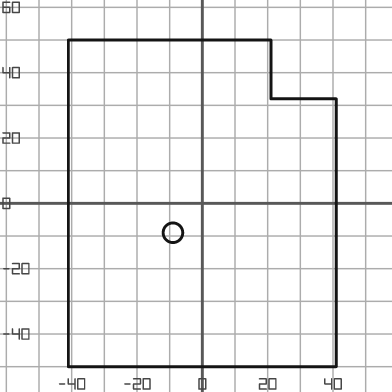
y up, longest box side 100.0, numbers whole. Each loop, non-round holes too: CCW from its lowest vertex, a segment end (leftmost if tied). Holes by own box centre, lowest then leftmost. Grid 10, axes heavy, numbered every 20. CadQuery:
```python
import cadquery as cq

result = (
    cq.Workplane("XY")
    .moveTo(-41.0, -50.0)
    .lineTo(41.0, -50.0)
    .lineTo(41.0, 32.0)
    .lineTo(21.0, 32.0)
    .lineTo(21.0, 50.0)
    .lineTo(-41.0, 50.0)
    .close()
    .moveTo(-9.0, -9.0)
    .circle(3.0)
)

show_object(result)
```